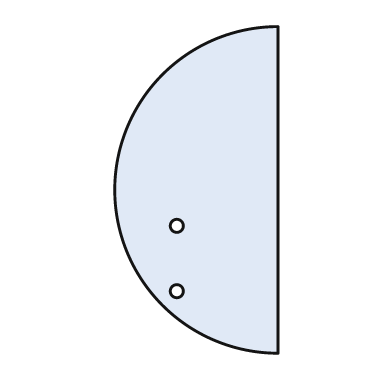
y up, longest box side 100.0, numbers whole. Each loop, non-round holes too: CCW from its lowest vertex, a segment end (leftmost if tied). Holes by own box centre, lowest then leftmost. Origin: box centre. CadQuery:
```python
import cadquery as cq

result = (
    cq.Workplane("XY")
    .moveTo(25.0, -50.0)
    .lineTo(25.0, 50.0)
    .threePointArc((-25.0, 0.0), (25.0, -50.0))
    .close()
    .moveTo(-6.0, -31.0)
    .circle(2.0)
    .moveTo(-6.0, -11.0)
    .circle(2.0)
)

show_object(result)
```